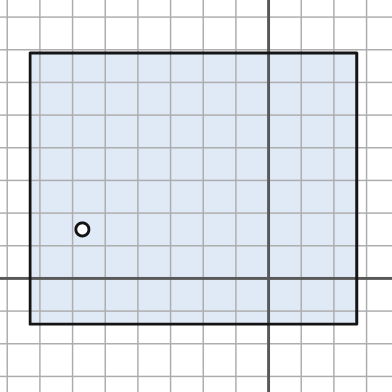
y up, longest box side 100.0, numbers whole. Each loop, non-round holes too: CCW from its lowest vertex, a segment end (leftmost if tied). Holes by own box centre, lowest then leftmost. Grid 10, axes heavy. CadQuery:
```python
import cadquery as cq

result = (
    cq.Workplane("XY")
    .moveTo(-73.0, -14.0)
    .lineTo(27.0, -14.0)
    .lineTo(27.0, 69.0)
    .lineTo(-73.0, 69.0)
    .close()
    .moveTo(-57.0, 15.0)
    .circle(2.0)
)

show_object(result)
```